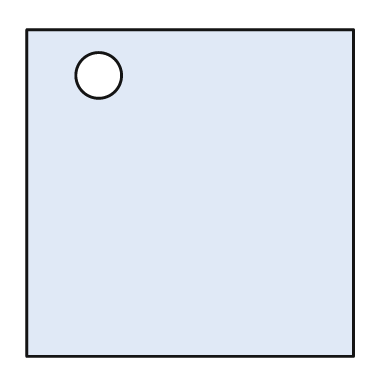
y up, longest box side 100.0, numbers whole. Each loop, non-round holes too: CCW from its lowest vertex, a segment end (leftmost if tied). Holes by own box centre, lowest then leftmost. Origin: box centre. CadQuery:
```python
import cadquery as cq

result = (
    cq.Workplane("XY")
    .moveTo(-50.0, -50.0)
    .lineTo(50.0, -50.0)
    .lineTo(50.0, 50.0)
    .lineTo(-50.0, 50.0)
    .close()
    .moveTo(-28.0, 36.0)
    .circle(7.0)
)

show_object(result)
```